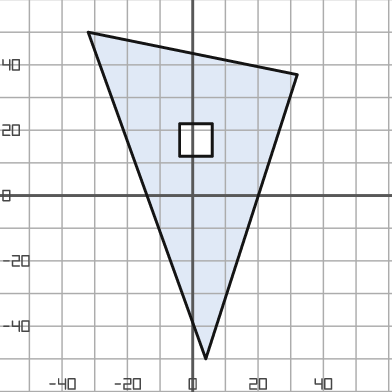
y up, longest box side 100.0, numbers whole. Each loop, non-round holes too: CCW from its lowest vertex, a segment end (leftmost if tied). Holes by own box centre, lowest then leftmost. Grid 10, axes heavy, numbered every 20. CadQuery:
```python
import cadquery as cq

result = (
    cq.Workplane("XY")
    .moveTo(4.0, -50.0)
    .lineTo(32.0, 37.0)
    .lineTo(-32.0, 50.0)
    .close()
    .moveTo(-4.0, 12.0)
    .lineTo(6.0, 12.0)
    .lineTo(6.0, 22.0)
    .lineTo(-4.0, 22.0)
    .close()
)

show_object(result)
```